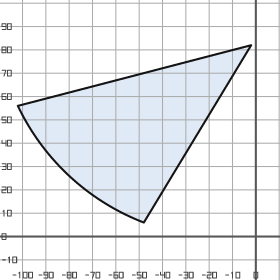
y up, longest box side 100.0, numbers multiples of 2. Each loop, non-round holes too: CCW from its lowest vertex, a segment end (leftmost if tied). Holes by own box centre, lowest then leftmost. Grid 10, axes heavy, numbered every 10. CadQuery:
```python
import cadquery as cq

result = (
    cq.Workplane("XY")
    .moveTo(-48.0, 6.0)
    .lineTo(-2.0, 82.0)
    .lineTo(-102.0, 56.0)
    .threePointArc((-80.0, 26.0), (-48.0, 6.0))
    .close()
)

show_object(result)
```